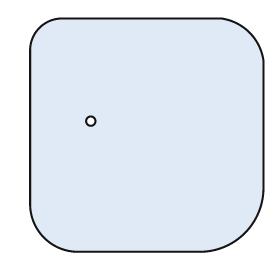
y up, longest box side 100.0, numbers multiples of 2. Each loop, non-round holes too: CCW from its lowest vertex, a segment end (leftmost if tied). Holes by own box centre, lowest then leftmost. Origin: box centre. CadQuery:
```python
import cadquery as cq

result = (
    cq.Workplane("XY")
    .moveTo(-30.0, -50.0)
    .lineTo(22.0, -50.0)
    .threePointArc((42.0, -42.0), (50.0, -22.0))
    .lineTo(50.0, 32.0)
    .threePointArc((44.0, 44.0), (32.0, 50.0))
    .lineTo(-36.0, 50.0)
    .threePointArc((-46.0, 46.0), (-50.0, 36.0))
    .lineTo(-50.0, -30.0)
    .threePointArc((-44.0, -44.0), (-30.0, -50.0))
    .close()
    .moveTo(-24.0, 6.0)
    .circle(2.0)
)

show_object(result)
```